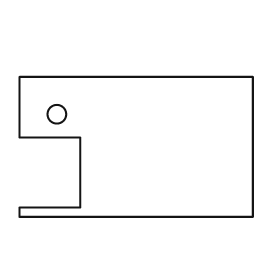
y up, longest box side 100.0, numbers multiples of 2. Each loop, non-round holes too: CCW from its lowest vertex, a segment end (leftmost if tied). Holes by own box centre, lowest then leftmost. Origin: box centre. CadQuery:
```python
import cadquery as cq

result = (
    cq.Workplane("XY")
    .moveTo(-50.0, -30.0)
    .lineTo(50.0, -30.0)
    .lineTo(50.0, 30.0)
    .lineTo(-50.0, 30.0)
    .lineTo(-50.0, 4.0)
    .lineTo(-24.0, 4.0)
    .lineTo(-24.0, -26.0)
    .lineTo(-50.0, -26.0)
    .close()
    .moveTo(-34.0, 14.0)
    .circle(4.0)
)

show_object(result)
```